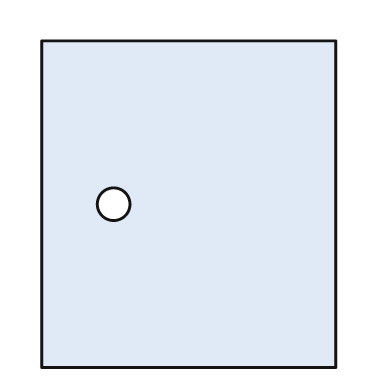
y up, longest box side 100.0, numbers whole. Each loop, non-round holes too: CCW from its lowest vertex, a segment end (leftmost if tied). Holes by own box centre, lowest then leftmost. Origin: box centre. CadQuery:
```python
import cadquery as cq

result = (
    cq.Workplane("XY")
    .moveTo(-45.0, -50.0)
    .lineTo(45.0, -50.0)
    .lineTo(45.0, 50.0)
    .lineTo(-45.0, 50.0)
    .close()
    .moveTo(-23.0, 0.0)
    .circle(5.0)
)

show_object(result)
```